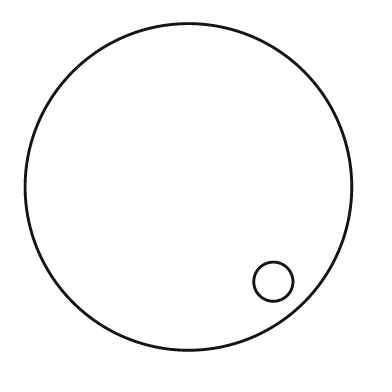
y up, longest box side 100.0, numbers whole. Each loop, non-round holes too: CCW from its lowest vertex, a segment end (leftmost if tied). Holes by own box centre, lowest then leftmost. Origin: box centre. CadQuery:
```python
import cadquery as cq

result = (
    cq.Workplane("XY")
    .moveTo(0.0, 0.0)
    .circle(50.0)
    .moveTo(26.0, -29.0)
    .circle(6.0)
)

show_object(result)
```